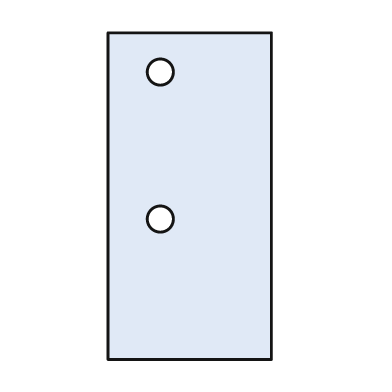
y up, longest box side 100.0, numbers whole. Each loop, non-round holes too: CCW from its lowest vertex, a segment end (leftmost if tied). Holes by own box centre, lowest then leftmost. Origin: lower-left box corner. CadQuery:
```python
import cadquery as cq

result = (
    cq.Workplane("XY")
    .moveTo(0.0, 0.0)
    .lineTo(50.0, 0.0)
    .lineTo(50.0, 100.0)
    .lineTo(0.0, 100.0)
    .close()
    .moveTo(16.0, 43.0)
    .circle(4.0)
    .moveTo(16.0, 88.0)
    .circle(4.0)
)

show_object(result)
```